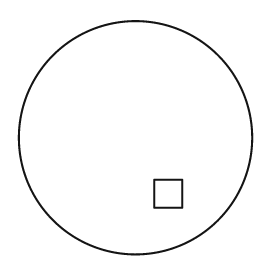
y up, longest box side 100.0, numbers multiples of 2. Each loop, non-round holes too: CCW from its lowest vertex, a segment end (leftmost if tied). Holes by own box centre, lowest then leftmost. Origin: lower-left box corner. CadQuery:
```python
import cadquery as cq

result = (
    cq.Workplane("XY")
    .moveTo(50.0, 50.0)
    .circle(50.0)
    .moveTo(58.0, 20.0)
    .lineTo(70.0, 20.0)
    .lineTo(70.0, 32.0)
    .lineTo(58.0, 32.0)
    .close()
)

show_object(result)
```